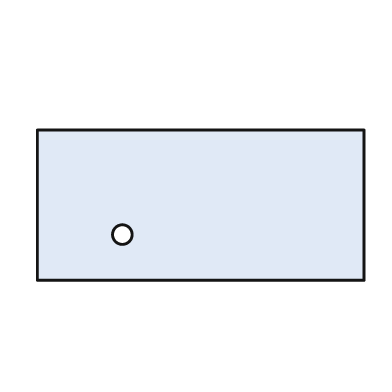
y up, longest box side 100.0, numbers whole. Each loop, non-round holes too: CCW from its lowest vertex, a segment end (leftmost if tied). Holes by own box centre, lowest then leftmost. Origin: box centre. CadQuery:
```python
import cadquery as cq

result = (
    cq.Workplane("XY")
    .moveTo(-50.0, -23.0)
    .lineTo(50.0, -23.0)
    .lineTo(50.0, 23.0)
    .lineTo(-50.0, 23.0)
    .close()
    .moveTo(-24.0, -9.0)
    .circle(3.0)
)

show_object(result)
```